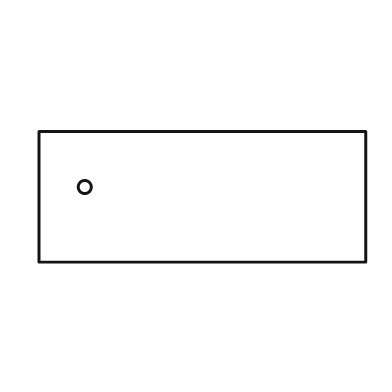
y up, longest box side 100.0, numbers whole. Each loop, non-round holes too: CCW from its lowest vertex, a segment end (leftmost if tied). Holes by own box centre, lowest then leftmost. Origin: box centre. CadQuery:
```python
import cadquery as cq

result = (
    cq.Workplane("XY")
    .moveTo(-50.0, -20.0)
    .lineTo(50.0, -20.0)
    .lineTo(50.0, 20.0)
    .lineTo(-50.0, 20.0)
    .close()
    .moveTo(-36.0, 3.0)
    .circle(2.0)
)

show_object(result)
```